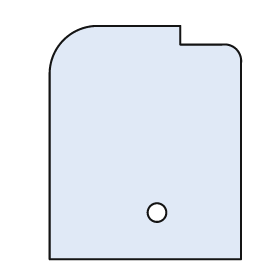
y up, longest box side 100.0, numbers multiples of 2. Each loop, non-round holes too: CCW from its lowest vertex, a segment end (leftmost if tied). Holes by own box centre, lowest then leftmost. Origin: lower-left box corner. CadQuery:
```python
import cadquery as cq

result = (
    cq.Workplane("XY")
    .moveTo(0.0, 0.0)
    .lineTo(82.0, 0.0)
    .lineTo(82.0, 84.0)
    .threePointArc((80.0, 90.0), (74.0, 92.0))
    .lineTo(56.0, 92.0)
    .lineTo(56.0, 100.0)
    .lineTo(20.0, 100.0)
    .threePointArc((6.0, 94.0), (0.0, 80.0))
    .close()
    .moveTo(46.0, 20.0)
    .circle(4.0)
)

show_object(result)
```